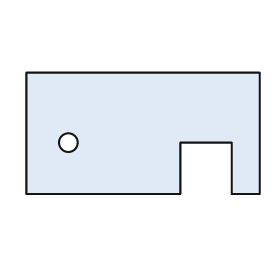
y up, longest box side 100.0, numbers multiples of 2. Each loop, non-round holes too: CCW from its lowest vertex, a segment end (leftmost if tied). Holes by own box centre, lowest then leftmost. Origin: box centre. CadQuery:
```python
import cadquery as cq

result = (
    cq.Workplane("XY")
    .moveTo(-50.0, -26.0)
    .lineTo(16.0, -26.0)
    .lineTo(16.0, -4.0)
    .lineTo(38.0, -4.0)
    .lineTo(38.0, -26.0)
    .lineTo(50.0, -26.0)
    .lineTo(50.0, 26.0)
    .lineTo(-50.0, 26.0)
    .close()
    .moveTo(-32.0, -4.0)
    .circle(4.0)
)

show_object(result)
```